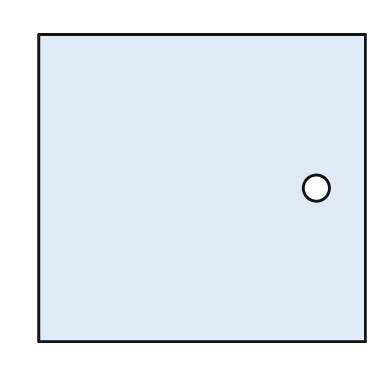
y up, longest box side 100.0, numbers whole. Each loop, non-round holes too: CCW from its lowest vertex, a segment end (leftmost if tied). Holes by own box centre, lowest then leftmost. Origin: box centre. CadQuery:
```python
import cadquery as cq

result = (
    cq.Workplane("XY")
    .moveTo(-50.0, -47.0)
    .lineTo(50.0, -47.0)
    .lineTo(50.0, 47.0)
    .lineTo(-50.0, 47.0)
    .close()
    .moveTo(35.0, 0.0)
    .circle(4.0)
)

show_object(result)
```